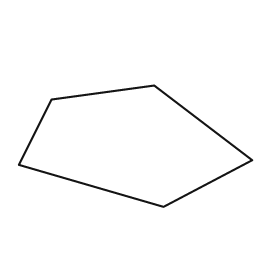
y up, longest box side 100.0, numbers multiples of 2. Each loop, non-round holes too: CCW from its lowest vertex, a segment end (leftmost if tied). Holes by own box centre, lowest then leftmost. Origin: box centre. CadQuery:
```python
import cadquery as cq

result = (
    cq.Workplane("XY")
    .moveTo(12.0, -26.0)
    .lineTo(50.0, -6.0)
    .lineTo(8.0, 26.0)
    .lineTo(-36.0, 20.0)
    .lineTo(-50.0, -8.0)
    .close()
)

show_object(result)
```